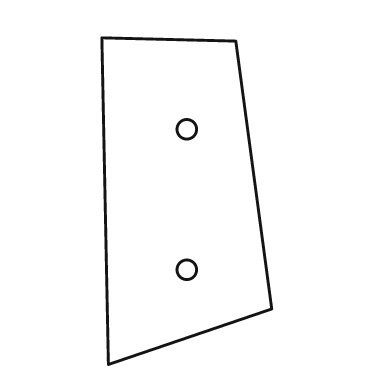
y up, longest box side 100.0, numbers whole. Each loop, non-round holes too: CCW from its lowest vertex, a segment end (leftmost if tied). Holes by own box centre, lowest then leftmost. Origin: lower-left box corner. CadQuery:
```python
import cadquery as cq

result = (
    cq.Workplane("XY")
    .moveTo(2.0, 0.0)
    .lineTo(52.0, 17.0)
    .lineTo(41.0, 99.0)
    .lineTo(0.0, 100.0)
    .close()
    .moveTo(26.0, 29.0)
    .circle(3.0)
    .moveTo(26.0, 72.0)
    .circle(3.0)
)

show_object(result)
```